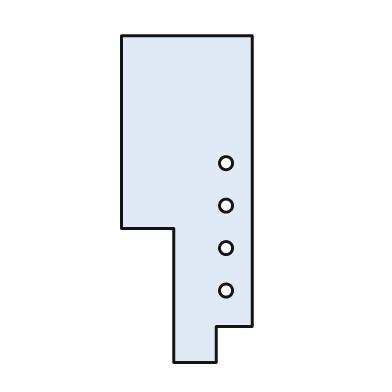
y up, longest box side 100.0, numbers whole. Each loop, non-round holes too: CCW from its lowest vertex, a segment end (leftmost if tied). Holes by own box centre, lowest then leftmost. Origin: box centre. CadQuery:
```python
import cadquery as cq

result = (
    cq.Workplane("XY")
    .moveTo(-4.0, -50.0)
    .lineTo(9.0, -50.0)
    .lineTo(9.0, -39.0)
    .lineTo(20.0, -39.0)
    .lineTo(20.0, 50.0)
    .lineTo(-20.0, 50.0)
    .lineTo(-20.0, -9.0)
    .lineTo(-4.0, -9.0)
    .close()
    .moveTo(12.0, -28.0)
    .circle(2.0)
    .moveTo(12.0, -15.0)
    .circle(2.0)
    .moveTo(12.0, -2.0)
    .circle(2.0)
    .moveTo(12.0, 11.0)
    .circle(2.0)
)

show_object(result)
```